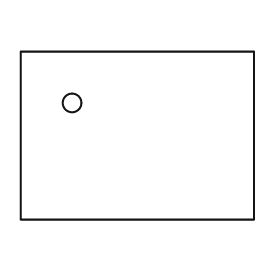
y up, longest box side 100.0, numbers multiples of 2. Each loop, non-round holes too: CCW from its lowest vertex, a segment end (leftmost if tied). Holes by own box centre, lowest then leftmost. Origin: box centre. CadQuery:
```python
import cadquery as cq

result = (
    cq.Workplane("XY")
    .moveTo(-50.0, -36.0)
    .lineTo(50.0, -36.0)
    .lineTo(50.0, 36.0)
    .lineTo(-50.0, 36.0)
    .close()
    .moveTo(-28.0, 14.0)
    .circle(4.0)
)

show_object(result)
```